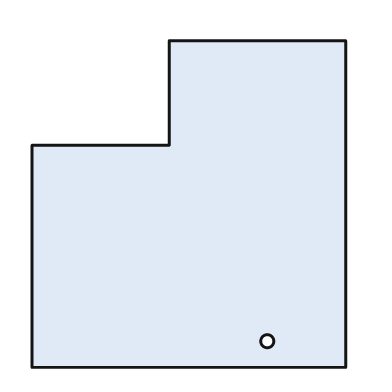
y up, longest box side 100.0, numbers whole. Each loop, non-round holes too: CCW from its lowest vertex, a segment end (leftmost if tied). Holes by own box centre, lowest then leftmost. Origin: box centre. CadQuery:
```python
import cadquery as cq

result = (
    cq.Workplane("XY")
    .moveTo(-48.0, -50.0)
    .lineTo(48.0, -50.0)
    .lineTo(48.0, 50.0)
    .lineTo(-6.0, 50.0)
    .lineTo(-6.0, 18.0)
    .lineTo(-48.0, 18.0)
    .close()
    .moveTo(24.0, -42.0)
    .circle(2.0)
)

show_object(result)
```